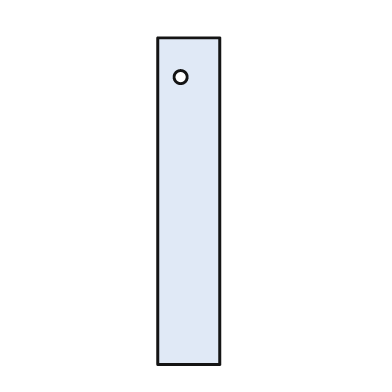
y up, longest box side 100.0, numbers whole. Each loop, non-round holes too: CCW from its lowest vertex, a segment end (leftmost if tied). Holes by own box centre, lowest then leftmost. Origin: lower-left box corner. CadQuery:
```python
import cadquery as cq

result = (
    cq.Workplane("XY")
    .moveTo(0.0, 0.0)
    .lineTo(19.0, 0.0)
    .lineTo(19.0, 100.0)
    .lineTo(0.0, 100.0)
    .close()
    .moveTo(7.0, 88.0)
    .circle(2.0)
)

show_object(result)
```